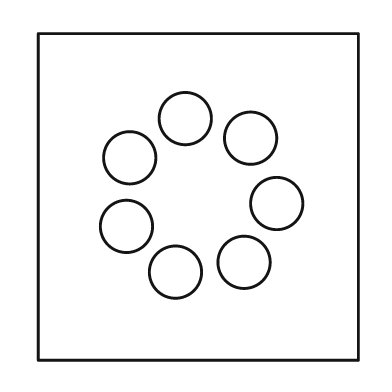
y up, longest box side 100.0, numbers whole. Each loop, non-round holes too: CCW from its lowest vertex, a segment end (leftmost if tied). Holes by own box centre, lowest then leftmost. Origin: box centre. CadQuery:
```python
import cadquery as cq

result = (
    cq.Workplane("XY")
    .moveTo(-49.0, -50.0)
    .lineTo(49.0, -50.0)
    .lineTo(49.0, 50.0)
    .lineTo(-49.0, 50.0)
    .close()
    .moveTo(-7.0, -23.0)
    .circle(8.0)
    .moveTo(14.0, -20.0)
    .circle(8.0)
    .moveTo(-22.0, -9.0)
    .circle(8.0)
    .moveTo(24.0, -2.0)
    .circle(8.0)
    .moveTo(-21.0, 12.0)
    .circle(8.0)
    .moveTo(16.0, 18.0)
    .circle(8.0)
    .moveTo(-4.0, 24.0)
    .circle(8.0)
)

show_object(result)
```